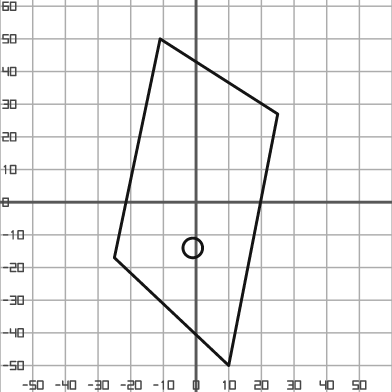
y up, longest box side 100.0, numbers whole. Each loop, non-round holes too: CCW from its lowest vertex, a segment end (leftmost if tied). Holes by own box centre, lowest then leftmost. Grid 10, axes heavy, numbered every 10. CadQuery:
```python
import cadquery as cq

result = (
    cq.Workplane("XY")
    .moveTo(10.0, -50.0)
    .lineTo(25.0, 27.0)
    .lineTo(-11.0, 50.0)
    .lineTo(-25.0, -17.0)
    .close()
    .moveTo(-1.0, -14.0)
    .circle(3.0)
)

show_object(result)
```